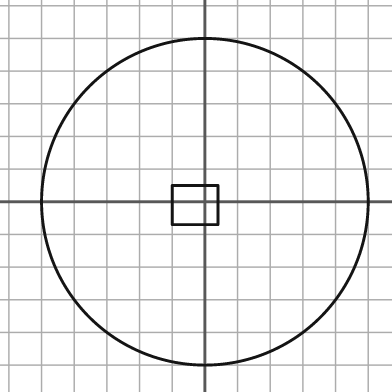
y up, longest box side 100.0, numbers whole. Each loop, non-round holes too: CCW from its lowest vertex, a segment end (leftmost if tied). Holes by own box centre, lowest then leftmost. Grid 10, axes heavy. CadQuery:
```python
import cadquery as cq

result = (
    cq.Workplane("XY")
    .moveTo(0.0, 0.0)
    .circle(50.0)
    .moveTo(-10.0, -7.0)
    .lineTo(4.0, -7.0)
    .lineTo(4.0, 5.0)
    .lineTo(-10.0, 5.0)
    .close()
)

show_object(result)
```